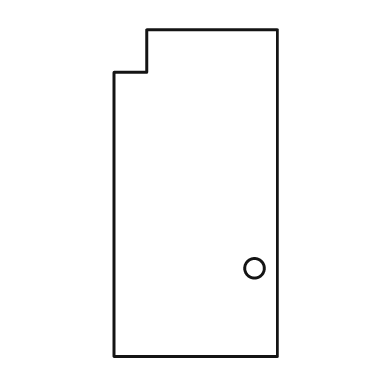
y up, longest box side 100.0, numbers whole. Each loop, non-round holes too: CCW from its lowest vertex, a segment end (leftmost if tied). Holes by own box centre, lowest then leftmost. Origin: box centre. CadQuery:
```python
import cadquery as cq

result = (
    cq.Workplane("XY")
    .moveTo(-25.0, -50.0)
    .lineTo(25.0, -50.0)
    .lineTo(25.0, 50.0)
    .lineTo(-15.0, 50.0)
    .lineTo(-15.0, 37.0)
    .lineTo(-25.0, 37.0)
    .close()
    .moveTo(18.0, -23.0)
    .circle(3.0)
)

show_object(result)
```